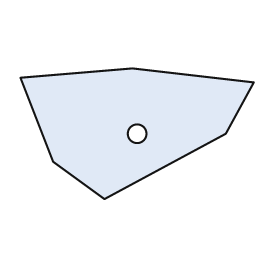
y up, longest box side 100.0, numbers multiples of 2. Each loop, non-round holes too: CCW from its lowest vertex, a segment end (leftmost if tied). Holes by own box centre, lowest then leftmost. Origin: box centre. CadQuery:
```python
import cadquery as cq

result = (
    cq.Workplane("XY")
    .moveTo(-14.0, -28.0)
    .lineTo(38.0, 0.0)
    .lineTo(50.0, 22.0)
    .lineTo(-2.0, 28.0)
    .lineTo(-50.0, 24.0)
    .lineTo(-36.0, -12.0)
    .close()
    .moveTo(0.0, 0.0)
    .circle(4.0)
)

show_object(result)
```